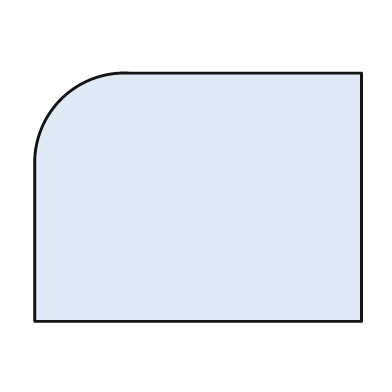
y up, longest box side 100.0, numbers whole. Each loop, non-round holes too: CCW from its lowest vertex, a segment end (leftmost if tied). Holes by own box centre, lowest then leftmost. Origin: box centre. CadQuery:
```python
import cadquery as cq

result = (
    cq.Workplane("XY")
    .moveTo(-50.0, -38.0)
    .lineTo(50.0, -38.0)
    .lineTo(50.0, 38.0)
    .lineTo(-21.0, 38.0)
    .threePointArc((-42.0, 30.0), (-50.0, 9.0))
    .close()
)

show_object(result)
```